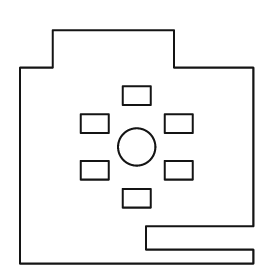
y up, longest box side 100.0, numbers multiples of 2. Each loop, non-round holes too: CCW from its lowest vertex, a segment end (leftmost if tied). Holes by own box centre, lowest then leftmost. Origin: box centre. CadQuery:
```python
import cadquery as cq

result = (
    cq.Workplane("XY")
    .moveTo(-50.0, -50.0)
    .lineTo(50.0, -50.0)
    .lineTo(50.0, -44.0)
    .lineTo(4.0, -44.0)
    .lineTo(4.0, -34.0)
    .lineTo(50.0, -34.0)
    .lineTo(50.0, 34.0)
    .lineTo(16.0, 34.0)
    .lineTo(16.0, 50.0)
    .lineTo(-36.0, 50.0)
    .lineTo(-36.0, 34.0)
    .lineTo(-50.0, 34.0)
    .close()
    .moveTo(-6.0, -26.0)
    .lineTo(6.0, -26.0)
    .lineTo(6.0, -18.0)
    .lineTo(-6.0, -18.0)
    .close()
    .moveTo(-24.0, -14.0)
    .lineTo(-12.0, -14.0)
    .lineTo(-12.0, -6.0)
    .lineTo(-24.0, -6.0)
    .close()
    .moveTo(12.0, -14.0)
    .lineTo(24.0, -14.0)
    .lineTo(24.0, -6.0)
    .lineTo(12.0, -6.0)
    .close()
    .moveTo(0.0, 0.0)
    .circle(8.0)
    .moveTo(-24.0, 6.0)
    .lineTo(-12.0, 6.0)
    .lineTo(-12.0, 14.0)
    .lineTo(-24.0, 14.0)
    .close()
    .moveTo(12.0, 6.0)
    .lineTo(24.0, 6.0)
    .lineTo(24.0, 14.0)
    .lineTo(12.0, 14.0)
    .close()
    .moveTo(-6.0, 18.0)
    .lineTo(6.0, 18.0)
    .lineTo(6.0, 26.0)
    .lineTo(-6.0, 26.0)
    .close()
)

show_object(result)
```